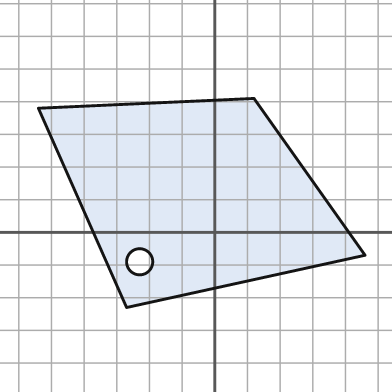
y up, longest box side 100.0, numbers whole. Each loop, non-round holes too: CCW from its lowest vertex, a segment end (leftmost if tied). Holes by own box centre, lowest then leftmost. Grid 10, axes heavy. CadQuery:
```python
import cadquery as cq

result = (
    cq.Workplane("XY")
    .moveTo(-27.0, -23.0)
    .lineTo(46.0, -7.0)
    .lineTo(12.0, 41.0)
    .lineTo(-54.0, 38.0)
    .close()
    .moveTo(-23.0, -9.0)
    .circle(4.0)
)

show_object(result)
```